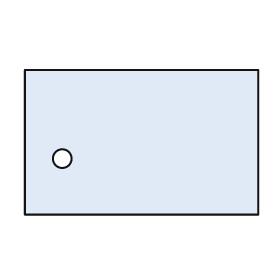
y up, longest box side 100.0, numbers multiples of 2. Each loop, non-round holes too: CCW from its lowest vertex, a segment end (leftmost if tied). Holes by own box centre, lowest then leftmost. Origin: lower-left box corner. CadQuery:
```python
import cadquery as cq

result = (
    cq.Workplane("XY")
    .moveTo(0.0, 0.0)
    .lineTo(100.0, 0.0)
    .lineTo(100.0, 62.0)
    .lineTo(0.0, 62.0)
    .close()
    .moveTo(16.0, 24.0)
    .circle(4.0)
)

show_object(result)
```